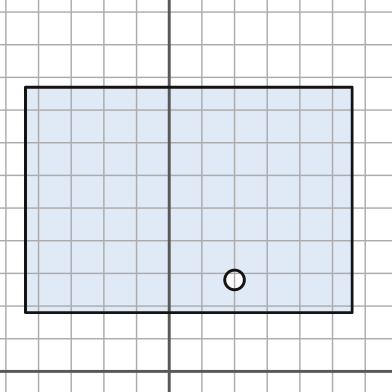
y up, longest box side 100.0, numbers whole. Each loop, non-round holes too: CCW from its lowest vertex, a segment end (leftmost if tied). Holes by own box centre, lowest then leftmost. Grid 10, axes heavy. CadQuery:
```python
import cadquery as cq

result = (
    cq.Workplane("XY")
    .moveTo(-44.0, 18.0)
    .lineTo(56.0, 18.0)
    .lineTo(56.0, 87.0)
    .lineTo(-44.0, 87.0)
    .close()
    .moveTo(20.0, 28.0)
    .circle(3.0)
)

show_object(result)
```